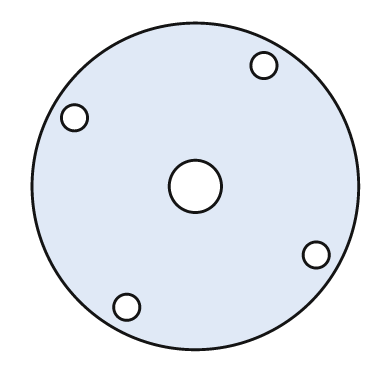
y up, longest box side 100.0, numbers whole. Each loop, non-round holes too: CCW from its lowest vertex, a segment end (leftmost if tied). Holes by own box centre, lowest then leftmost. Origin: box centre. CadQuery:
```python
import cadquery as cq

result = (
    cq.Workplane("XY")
    .moveTo(0.0, 0.0)
    .circle(50.0)
    .moveTo(-21.0, -37.0)
    .circle(4.0)
    .moveTo(37.0, -21.0)
    .circle(4.0)
    .moveTo(0.0, 0.0)
    .circle(8.0)
    .moveTo(-37.0, 21.0)
    .circle(4.0)
    .moveTo(21.0, 37.0)
    .circle(4.0)
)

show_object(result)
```